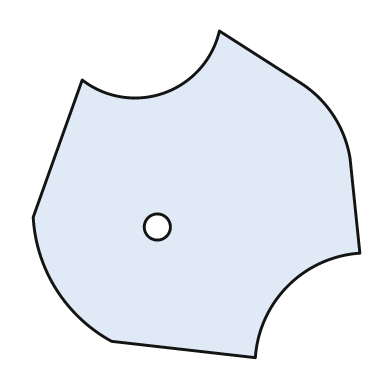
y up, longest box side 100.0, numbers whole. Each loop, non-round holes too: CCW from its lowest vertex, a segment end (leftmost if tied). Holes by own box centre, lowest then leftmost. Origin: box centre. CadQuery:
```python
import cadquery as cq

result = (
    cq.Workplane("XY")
    .moveTo(18.0, -50.0)
    .threePointArc((28.0, -28.0), (50.0, -18.0))
    .lineTo(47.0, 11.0)
    .threePointArc((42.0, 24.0), (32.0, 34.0))
    .lineTo(7.0, 50.0)
    .threePointArc((-10.0, 31.0), (-35.0, 35.0))
    .lineTo(-50.0, -7.0)
    .threePointArc((-43.0, -29.0), (-26.0, -45.0))
    .close()
    .moveTo(-12.0, -10.0)
    .circle(4.0)
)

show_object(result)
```